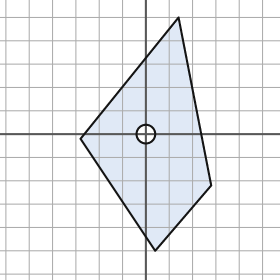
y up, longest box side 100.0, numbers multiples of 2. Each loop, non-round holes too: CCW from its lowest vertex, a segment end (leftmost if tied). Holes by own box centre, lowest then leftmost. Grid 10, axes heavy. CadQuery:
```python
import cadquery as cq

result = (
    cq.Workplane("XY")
    .moveTo(4.0, -50.0)
    .lineTo(28.0, -22.0)
    .lineTo(14.0, 50.0)
    .lineTo(-28.0, -2.0)
    .close()
    .moveTo(0.0, 0.0)
    .circle(4.0)
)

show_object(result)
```